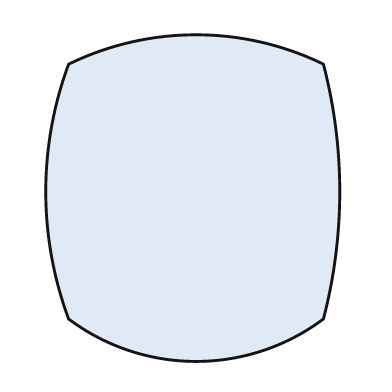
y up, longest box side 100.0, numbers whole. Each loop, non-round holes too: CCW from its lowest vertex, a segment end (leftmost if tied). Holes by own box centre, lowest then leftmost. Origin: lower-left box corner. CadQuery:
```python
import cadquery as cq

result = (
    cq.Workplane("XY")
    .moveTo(7.0, 13.0)
    .threePointArc((46.0, 0.0), (85.0, 13.0))
    .threePointArc((90.0, 52.0), (85.0, 91.0))
    .threePointArc((46.0, 100.0), (7.0, 91.0))
    .threePointArc((0.0, 52.0), (7.0, 13.0))
    .close()
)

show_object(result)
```